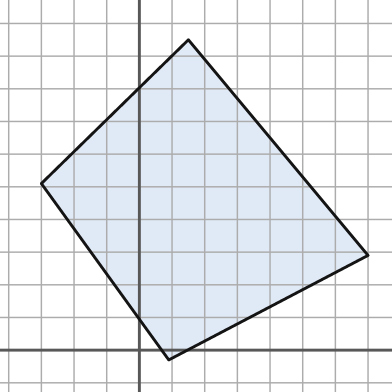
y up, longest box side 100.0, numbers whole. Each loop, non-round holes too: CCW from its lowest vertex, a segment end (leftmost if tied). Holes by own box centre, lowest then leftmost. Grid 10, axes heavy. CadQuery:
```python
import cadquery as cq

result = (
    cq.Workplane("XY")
    .moveTo(9.0, -3.0)
    .lineTo(70.0, 29.0)
    .lineTo(15.0, 95.0)
    .lineTo(-30.0, 51.0)
    .close()
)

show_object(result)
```